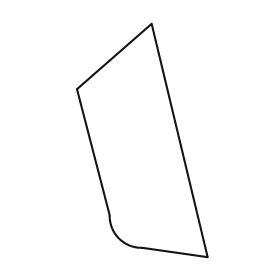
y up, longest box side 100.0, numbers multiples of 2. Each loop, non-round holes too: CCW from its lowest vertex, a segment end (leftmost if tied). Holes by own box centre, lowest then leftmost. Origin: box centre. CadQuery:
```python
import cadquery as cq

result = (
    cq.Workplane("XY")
    .moveTo(28.0, -50.0)
    .lineTo(4.0, 50.0)
    .lineTo(-28.0, 22.0)
    .lineTo(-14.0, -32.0)
    .threePointArc((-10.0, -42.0), (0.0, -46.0))
    .close()
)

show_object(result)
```